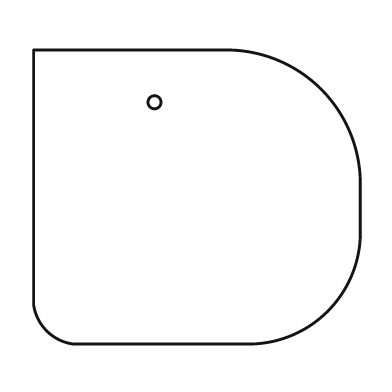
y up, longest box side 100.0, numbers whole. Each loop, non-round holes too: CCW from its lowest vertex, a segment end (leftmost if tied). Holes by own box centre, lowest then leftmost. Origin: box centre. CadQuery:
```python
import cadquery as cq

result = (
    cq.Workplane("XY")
    .moveTo(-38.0, -45.0)
    .lineTo(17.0, -45.0)
    .threePointArc((40.0, -35.0), (50.0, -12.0))
    .lineTo(50.0, 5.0)
    .threePointArc((38.0, 33.0), (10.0, 45.0))
    .lineTo(-50.0, 45.0)
    .lineTo(-50.0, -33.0)
    .threePointArc((-46.0, -41.0), (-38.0, -45.0))
    .close()
    .moveTo(-13.0, 29.0)
    .circle(2.0)
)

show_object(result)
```